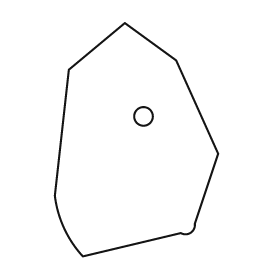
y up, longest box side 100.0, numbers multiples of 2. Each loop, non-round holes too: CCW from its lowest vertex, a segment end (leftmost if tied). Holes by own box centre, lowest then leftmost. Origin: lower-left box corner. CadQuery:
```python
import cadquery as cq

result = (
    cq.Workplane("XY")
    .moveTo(12.0, 0.0)
    .lineTo(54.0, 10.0)
    .threePointArc((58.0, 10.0), (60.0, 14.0))
    .lineTo(70.0, 44.0)
    .lineTo(52.0, 84.0)
    .lineTo(30.0, 100.0)
    .lineTo(6.0, 80.0)
    .lineTo(0.0, 26.0)
    .threePointArc((4.0, 12.0), (12.0, 0.0))
    .close()
    .moveTo(38.0, 60.0)
    .circle(4.0)
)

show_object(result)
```